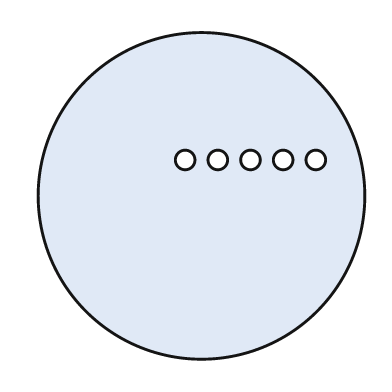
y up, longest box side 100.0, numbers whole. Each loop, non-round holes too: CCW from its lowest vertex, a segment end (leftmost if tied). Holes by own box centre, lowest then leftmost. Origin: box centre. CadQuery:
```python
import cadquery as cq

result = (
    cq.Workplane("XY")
    .moveTo(0.0, 0.0)
    .circle(50.0)
    .moveTo(-5.0, 11.0)
    .circle(3.0)
    .moveTo(5.0, 11.0)
    .circle(3.0)
    .moveTo(15.0, 11.0)
    .circle(3.0)
    .moveTo(25.0, 11.0)
    .circle(3.0)
    .moveTo(35.0, 11.0)
    .circle(3.0)
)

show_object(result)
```